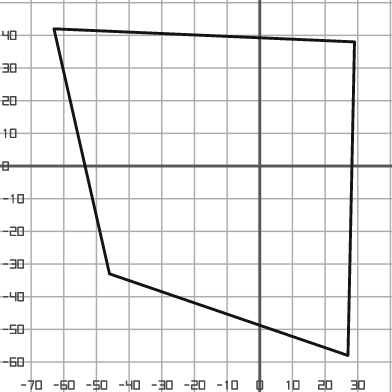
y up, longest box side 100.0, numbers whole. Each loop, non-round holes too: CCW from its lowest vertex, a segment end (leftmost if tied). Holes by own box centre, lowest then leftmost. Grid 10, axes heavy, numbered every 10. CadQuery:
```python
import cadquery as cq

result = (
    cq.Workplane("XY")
    .moveTo(27.0, -58.0)
    .lineTo(29.0, 38.0)
    .lineTo(-63.0, 42.0)
    .lineTo(-46.0, -33.0)
    .close()
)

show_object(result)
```